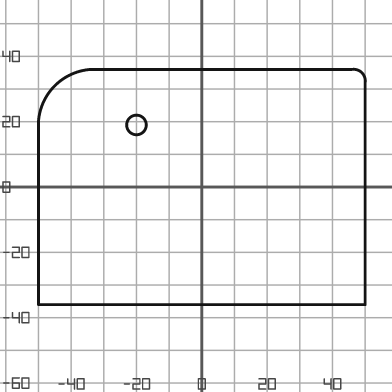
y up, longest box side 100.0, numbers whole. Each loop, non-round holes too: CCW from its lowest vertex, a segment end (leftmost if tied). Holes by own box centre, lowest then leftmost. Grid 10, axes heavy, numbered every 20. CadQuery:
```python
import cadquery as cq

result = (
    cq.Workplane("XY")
    .moveTo(-50.0, -36.0)
    .lineTo(50.0, -36.0)
    .lineTo(50.0, 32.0)
    .threePointArc((49.0, 35.0), (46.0, 36.0))
    .lineTo(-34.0, 36.0)
    .threePointArc((-45.0, 31.0), (-50.0, 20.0))
    .close()
    .moveTo(-20.0, 19.0)
    .circle(3.0)
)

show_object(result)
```